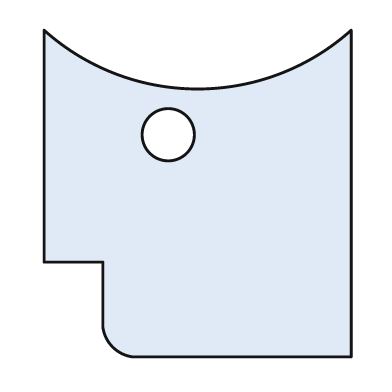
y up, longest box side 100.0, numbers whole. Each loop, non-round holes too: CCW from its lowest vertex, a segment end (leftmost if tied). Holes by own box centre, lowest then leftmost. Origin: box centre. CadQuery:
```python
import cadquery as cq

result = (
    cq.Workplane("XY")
    .moveTo(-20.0, -50.0)
    .lineTo(47.0, -50.0)
    .lineTo(47.0, 50.0)
    .threePointArc((0.0, 32.0), (-47.0, 50.0))
    .lineTo(-47.0, -21.0)
    .lineTo(-29.0, -21.0)
    .lineTo(-29.0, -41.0)
    .threePointArc((-26.0, -47.0), (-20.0, -50.0))
    .close()
    .moveTo(-9.0, 18.0)
    .circle(8.0)
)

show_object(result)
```